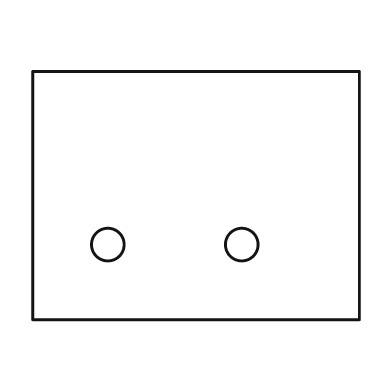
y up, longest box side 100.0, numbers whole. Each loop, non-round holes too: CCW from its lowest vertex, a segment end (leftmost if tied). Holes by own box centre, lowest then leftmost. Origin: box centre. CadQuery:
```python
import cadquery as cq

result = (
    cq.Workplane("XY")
    .moveTo(-50.0, -38.0)
    .lineTo(50.0, -38.0)
    .lineTo(50.0, 38.0)
    .lineTo(-50.0, 38.0)
    .close()
    .moveTo(-27.0, -15.0)
    .circle(5.0)
    .moveTo(14.0, -15.0)
    .circle(5.0)
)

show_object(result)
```